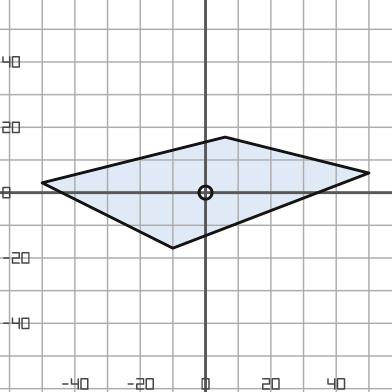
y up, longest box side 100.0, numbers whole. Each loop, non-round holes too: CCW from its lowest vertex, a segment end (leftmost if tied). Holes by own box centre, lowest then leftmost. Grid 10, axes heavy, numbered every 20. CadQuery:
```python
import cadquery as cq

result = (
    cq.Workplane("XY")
    .moveTo(-10.0, -17.0)
    .lineTo(50.0, 6.0)
    .lineTo(6.0, 17.0)
    .lineTo(-50.0, 3.0)
    .close()
    .moveTo(0.0, 0.0)
    .circle(2.0)
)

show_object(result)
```